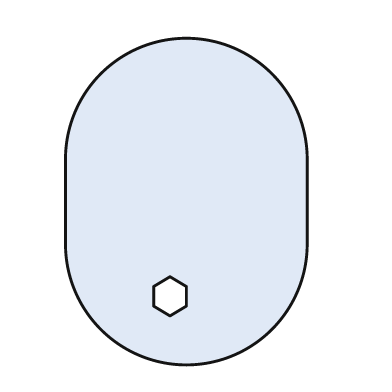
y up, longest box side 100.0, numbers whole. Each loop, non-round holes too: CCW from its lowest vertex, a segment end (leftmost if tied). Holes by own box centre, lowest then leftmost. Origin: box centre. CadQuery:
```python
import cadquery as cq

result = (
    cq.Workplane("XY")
    .moveTo(-37.0, -13.0)
    .threePointArc((0.0, -50.0), (37.0, -13.0))
    .lineTo(37.0, 13.0)
    .threePointArc((0.0, 50.0), (-37.0, 13.0))
    .close()
    .moveTo(-5.0, -35.0)
    .lineTo(0.0, -32.0)
    .lineTo(0.0, -26.0)
    .lineTo(-5.0, -23.0)
    .lineTo(-10.0, -26.0)
    .lineTo(-10.0, -32.0)
    .close()
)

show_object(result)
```